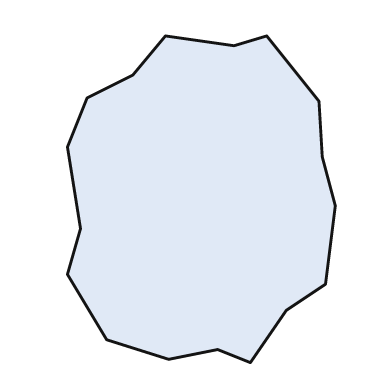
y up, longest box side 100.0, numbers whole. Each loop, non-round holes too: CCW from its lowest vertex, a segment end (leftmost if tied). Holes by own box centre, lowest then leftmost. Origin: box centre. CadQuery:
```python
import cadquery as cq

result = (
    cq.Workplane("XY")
    .moveTo(15.0, -50.0)
    .lineTo(26.0, -34.0)
    .lineTo(38.0, -26.0)
    .lineTo(41.0, -2.0)
    .lineTo(37.0, 13.0)
    .lineTo(36.0, 30.0)
    .lineTo(20.0, 50.0)
    .lineTo(10.0, 47.0)
    .lineTo(-11.0, 50.0)
    .lineTo(-21.0, 38.0)
    .lineTo(-35.0, 31.0)
    .lineTo(-41.0, 16.0)
    .lineTo(-37.0, -9.0)
    .lineTo(-41.0, -23.0)
    .lineTo(-29.0, -43.0)
    .lineTo(-10.0, -49.0)
    .lineTo(5.0, -46.0)
    .close()
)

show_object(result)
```